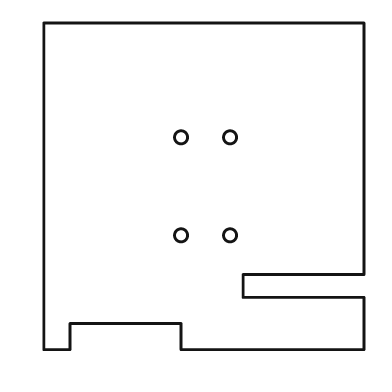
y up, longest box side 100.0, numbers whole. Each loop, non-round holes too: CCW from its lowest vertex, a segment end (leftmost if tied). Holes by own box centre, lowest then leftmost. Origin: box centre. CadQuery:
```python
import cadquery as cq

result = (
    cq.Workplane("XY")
    .moveTo(-49.0, -50.0)
    .lineTo(-41.0, -50.0)
    .lineTo(-41.0, -42.0)
    .lineTo(-7.0, -42.0)
    .lineTo(-7.0, -50.0)
    .lineTo(49.0, -50.0)
    .lineTo(49.0, -34.0)
    .lineTo(12.0, -34.0)
    .lineTo(12.0, -27.0)
    .lineTo(49.0, -27.0)
    .lineTo(49.0, 50.0)
    .lineTo(-49.0, 50.0)
    .close()
    .moveTo(-7.0, -15.0)
    .circle(2.0)
    .moveTo(8.0, -15.0)
    .circle(2.0)
    .moveTo(-7.0, 15.0)
    .circle(2.0)
    .moveTo(8.0, 15.0)
    .circle(2.0)
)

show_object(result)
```